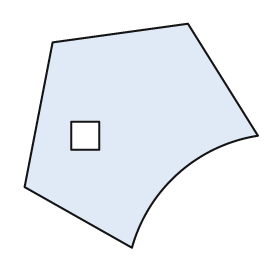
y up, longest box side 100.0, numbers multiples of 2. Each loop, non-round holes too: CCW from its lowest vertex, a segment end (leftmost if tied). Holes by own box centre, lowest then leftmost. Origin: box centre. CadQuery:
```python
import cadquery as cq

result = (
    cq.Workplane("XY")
    .moveTo(-4.0, -48.0)
    .threePointArc((16.0, -16.0), (50.0, 0.0))
    .lineTo(20.0, 48.0)
    .lineTo(-38.0, 40.0)
    .lineTo(-50.0, -22.0)
    .close()
    .moveTo(-30.0, -6.0)
    .lineTo(-18.0, -6.0)
    .lineTo(-18.0, 6.0)
    .lineTo(-30.0, 6.0)
    .close()
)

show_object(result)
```